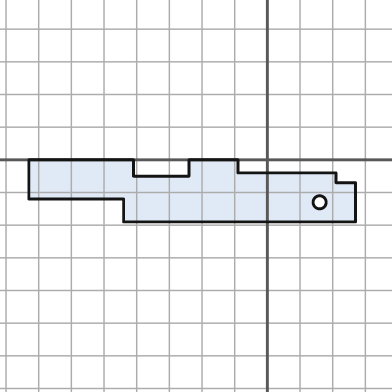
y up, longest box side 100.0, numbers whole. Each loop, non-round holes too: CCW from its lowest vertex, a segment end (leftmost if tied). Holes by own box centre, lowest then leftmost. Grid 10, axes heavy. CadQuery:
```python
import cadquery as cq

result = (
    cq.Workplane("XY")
    .moveTo(-44.0, -19.0)
    .lineTo(27.0, -19.0)
    .lineTo(27.0, -7.0)
    .lineTo(21.0, -7.0)
    .lineTo(21.0, -4.0)
    .lineTo(-9.0, -4.0)
    .lineTo(-9.0, 0.0)
    .lineTo(-24.0, 0.0)
    .lineTo(-24.0, -5.0)
    .lineTo(-41.0, -5.0)
    .lineTo(-41.0, 0.0)
    .lineTo(-73.0, 0.0)
    .lineTo(-73.0, -12.0)
    .lineTo(-44.0, -12.0)
    .close()
    .moveTo(16.0, -13.0)
    .circle(2.0)
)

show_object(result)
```